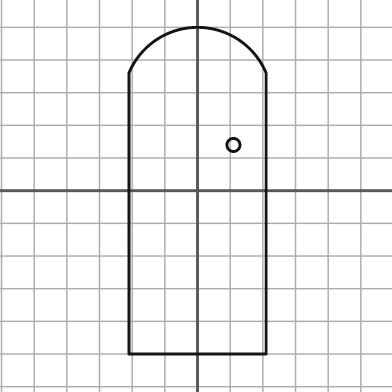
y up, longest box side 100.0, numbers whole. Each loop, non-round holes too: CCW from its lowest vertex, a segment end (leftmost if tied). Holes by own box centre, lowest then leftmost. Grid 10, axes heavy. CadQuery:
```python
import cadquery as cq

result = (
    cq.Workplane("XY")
    .moveTo(-21.0, -50.0)
    .lineTo(21.0, -50.0)
    .lineTo(21.0, 36.0)
    .threePointArc((0.0, 50.0), (-21.0, 36.0))
    .close()
    .moveTo(11.0, 14.0)
    .circle(2.0)
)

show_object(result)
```